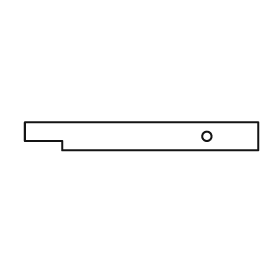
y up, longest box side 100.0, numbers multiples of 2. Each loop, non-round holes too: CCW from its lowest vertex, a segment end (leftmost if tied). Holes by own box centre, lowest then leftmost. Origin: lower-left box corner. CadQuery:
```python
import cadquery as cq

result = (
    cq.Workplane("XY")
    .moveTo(16.0, 0.0)
    .lineTo(100.0, 0.0)
    .lineTo(100.0, 12.0)
    .lineTo(0.0, 12.0)
    .lineTo(0.0, 4.0)
    .lineTo(16.0, 4.0)
    .close()
    .moveTo(78.0, 6.0)
    .circle(2.0)
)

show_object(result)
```